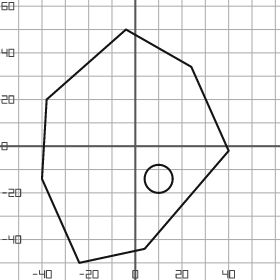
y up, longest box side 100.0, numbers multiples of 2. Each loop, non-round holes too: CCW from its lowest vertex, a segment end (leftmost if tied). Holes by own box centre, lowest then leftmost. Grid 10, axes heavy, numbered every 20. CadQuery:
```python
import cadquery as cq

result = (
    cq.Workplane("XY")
    .moveTo(-24.0, -50.0)
    .lineTo(4.0, -44.0)
    .lineTo(40.0, -2.0)
    .lineTo(24.0, 34.0)
    .lineTo(-4.0, 50.0)
    .lineTo(-38.0, 20.0)
    .lineTo(-40.0, -14.0)
    .close()
    .moveTo(10.0, -14.0)
    .circle(6.0)
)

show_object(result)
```